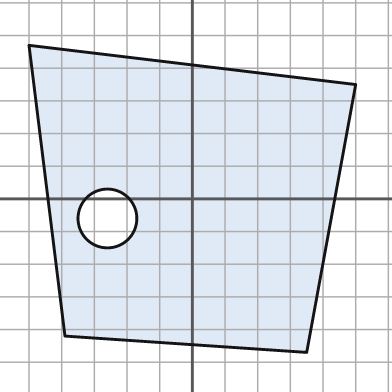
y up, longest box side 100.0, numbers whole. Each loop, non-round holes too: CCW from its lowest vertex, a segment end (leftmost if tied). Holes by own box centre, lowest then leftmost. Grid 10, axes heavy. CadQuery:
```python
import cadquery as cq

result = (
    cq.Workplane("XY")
    .moveTo(35.0, -47.0)
    .lineTo(50.0, 35.0)
    .lineTo(-50.0, 47.0)
    .lineTo(-39.0, -42.0)
    .close()
    .moveTo(-26.0, -6.0)
    .circle(9.0)
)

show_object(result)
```